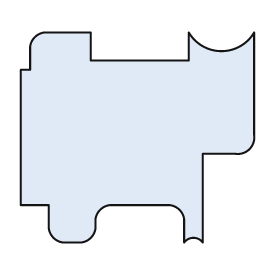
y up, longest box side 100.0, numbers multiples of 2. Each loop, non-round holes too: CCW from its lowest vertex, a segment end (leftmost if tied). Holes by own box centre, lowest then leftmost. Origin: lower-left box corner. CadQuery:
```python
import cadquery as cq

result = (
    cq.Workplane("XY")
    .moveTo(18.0, 0.0)
    .lineTo(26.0, 0.0)
    .threePointArc((30.0, 2.0), (32.0, 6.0))
    .lineTo(32.0, 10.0)
    .threePointArc((34.0, 14.0), (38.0, 16.0))
    .lineTo(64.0, 16.0)
    .threePointArc((68.0, 14.0), (70.0, 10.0))
    .lineTo(70.0, 0.0)
    .threePointArc((74.0, 2.0), (78.0, 0.0))
    .lineTo(78.0, 38.0)
    .lineTo(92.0, 38.0)
    .threePointArc((98.0, 40.0), (100.0, 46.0))
    .lineTo(100.0, 90.0)
    .threePointArc((86.0, 82.0), (72.0, 90.0))
    .lineTo(72.0, 78.0)
    .lineTo(30.0, 78.0)
    .lineTo(30.0, 90.0)
    .lineTo(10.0, 90.0)
    .threePointArc((6.0, 88.0), (4.0, 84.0))
    .lineTo(4.0, 74.0)
    .lineTo(0.0, 74.0)
    .lineTo(0.0, 16.0)
    .lineTo(12.0, 16.0)
    .lineTo(12.0, 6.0)
    .threePointArc((14.0, 2.0), (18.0, 0.0))
    .close()
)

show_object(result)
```